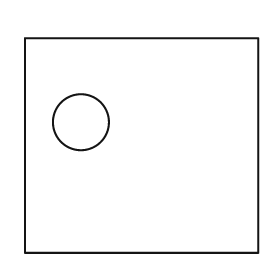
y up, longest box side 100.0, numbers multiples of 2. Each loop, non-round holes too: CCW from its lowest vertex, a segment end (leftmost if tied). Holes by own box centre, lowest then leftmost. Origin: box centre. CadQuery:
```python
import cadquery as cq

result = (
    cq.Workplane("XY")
    .moveTo(-50.0, -46.0)
    .lineTo(50.0, -46.0)
    .lineTo(50.0, 46.0)
    .lineTo(-50.0, 46.0)
    .close()
    .moveTo(-26.0, 10.0)
    .circle(12.0)
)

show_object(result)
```